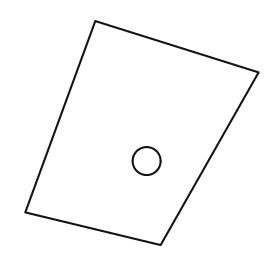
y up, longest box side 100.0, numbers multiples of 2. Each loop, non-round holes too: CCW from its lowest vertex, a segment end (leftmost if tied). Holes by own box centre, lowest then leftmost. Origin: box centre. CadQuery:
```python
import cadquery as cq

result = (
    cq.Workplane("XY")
    .moveTo(8.0, -48.0)
    .lineTo(50.0, 26.0)
    .lineTo(-20.0, 48.0)
    .lineTo(-50.0, -34.0)
    .close()
    .moveTo(2.0, -12.0)
    .circle(6.0)
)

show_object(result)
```